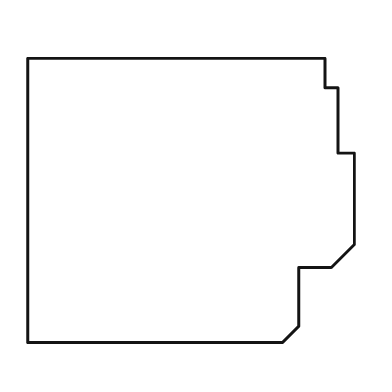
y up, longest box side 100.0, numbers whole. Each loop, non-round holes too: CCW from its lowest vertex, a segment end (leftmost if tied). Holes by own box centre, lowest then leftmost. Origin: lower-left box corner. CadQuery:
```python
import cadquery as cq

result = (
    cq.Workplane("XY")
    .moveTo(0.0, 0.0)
    .lineTo(78.0, 0.0)
    .lineTo(83.0, 5.0)
    .lineTo(83.0, 23.0)
    .lineTo(93.0, 23.0)
    .lineTo(100.0, 30.0)
    .lineTo(100.0, 58.0)
    .lineTo(95.0, 58.0)
    .lineTo(95.0, 78.0)
    .lineTo(91.0, 78.0)
    .lineTo(91.0, 87.0)
    .lineTo(0.0, 87.0)
    .close()
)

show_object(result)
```